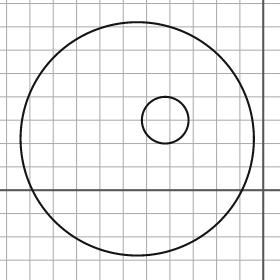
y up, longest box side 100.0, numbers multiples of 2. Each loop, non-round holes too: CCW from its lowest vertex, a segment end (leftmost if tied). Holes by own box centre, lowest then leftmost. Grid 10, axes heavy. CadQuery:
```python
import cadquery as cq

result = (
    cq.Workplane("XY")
    .moveTo(-54.0, 22.0)
    .circle(50.0)
    .moveTo(-42.0, 30.0)
    .circle(10.0)
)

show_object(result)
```